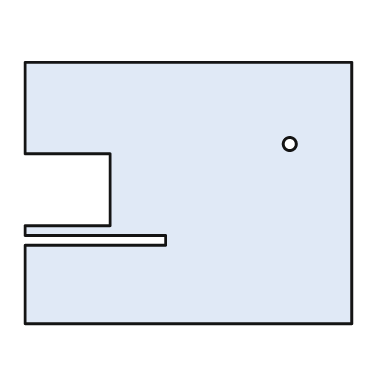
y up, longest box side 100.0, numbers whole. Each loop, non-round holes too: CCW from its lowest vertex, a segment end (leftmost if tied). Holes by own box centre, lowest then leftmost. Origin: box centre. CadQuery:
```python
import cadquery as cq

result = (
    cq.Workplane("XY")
    .moveTo(-50.0, -40.0)
    .lineTo(50.0, -40.0)
    .lineTo(50.0, 40.0)
    .lineTo(-50.0, 40.0)
    .lineTo(-50.0, 12.0)
    .lineTo(-24.0, 12.0)
    .lineTo(-24.0, -10.0)
    .lineTo(-50.0, -10.0)
    .lineTo(-50.0, -13.0)
    .lineTo(-7.0, -13.0)
    .lineTo(-7.0, -16.0)
    .lineTo(-50.0, -16.0)
    .close()
    .moveTo(31.0, 15.0)
    .circle(2.0)
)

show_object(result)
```